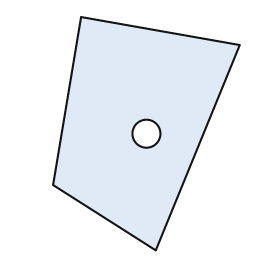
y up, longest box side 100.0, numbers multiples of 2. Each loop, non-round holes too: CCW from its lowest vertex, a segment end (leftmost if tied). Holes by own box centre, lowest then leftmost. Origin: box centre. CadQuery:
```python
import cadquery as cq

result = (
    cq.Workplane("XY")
    .moveTo(4.0, -50.0)
    .lineTo(40.0, 38.0)
    .lineTo(-28.0, 50.0)
    .lineTo(-40.0, -22.0)
    .close()
    .moveTo(0.0, 0.0)
    .circle(6.0)
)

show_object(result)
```